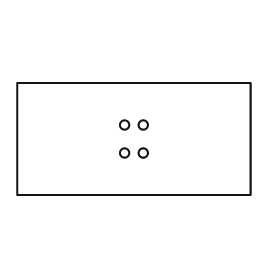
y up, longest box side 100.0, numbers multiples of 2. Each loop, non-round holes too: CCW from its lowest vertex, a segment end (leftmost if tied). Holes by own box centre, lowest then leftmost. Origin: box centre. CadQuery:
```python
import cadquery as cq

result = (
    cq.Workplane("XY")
    .moveTo(-50.0, -24.0)
    .lineTo(50.0, -24.0)
    .lineTo(50.0, 24.0)
    .lineTo(-50.0, 24.0)
    .close()
    .moveTo(-4.0, -6.0)
    .circle(2.0)
    .moveTo(4.0, -6.0)
    .circle(2.0)
    .moveTo(-4.0, 6.0)
    .circle(2.0)
    .moveTo(4.0, 6.0)
    .circle(2.0)
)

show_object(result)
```